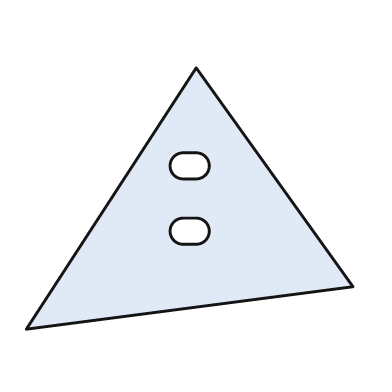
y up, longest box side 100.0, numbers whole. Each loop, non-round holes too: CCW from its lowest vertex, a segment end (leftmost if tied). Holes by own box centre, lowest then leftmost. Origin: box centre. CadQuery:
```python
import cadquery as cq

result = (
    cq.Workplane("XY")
    .moveTo(-50.0, -40.0)
    .lineTo(50.0, -27.0)
    .lineTo(2.0, 40.0)
    .close()
    .moveTo(-2.0, -14.0)
    .lineTo(2.0, -14.0)
    .threePointArc((6.0, -10.0), (2.0, -6.0))
    .lineTo(-2.0, -6.0)
    .threePointArc((-6.0, -10.0), (-2.0, -14.0))
    .close()
    .moveTo(-2.0, 6.0)
    .lineTo(2.0, 6.0)
    .threePointArc((6.0, 10.0), (2.0, 14.0))
    .lineTo(-2.0, 14.0)
    .threePointArc((-6.0, 10.0), (-2.0, 6.0))
    .close()
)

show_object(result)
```